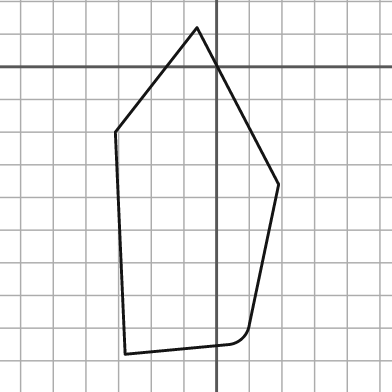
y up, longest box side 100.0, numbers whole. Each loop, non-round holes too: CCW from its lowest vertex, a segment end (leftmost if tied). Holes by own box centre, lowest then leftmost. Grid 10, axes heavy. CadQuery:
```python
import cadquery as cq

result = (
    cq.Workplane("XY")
    .moveTo(-28.0, -88.0)
    .lineTo(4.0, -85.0)
    .threePointArc((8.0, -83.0), (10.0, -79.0))
    .lineTo(19.0, -36.0)
    .lineTo(-6.0, 12.0)
    .lineTo(-31.0, -20.0)
    .close()
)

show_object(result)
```